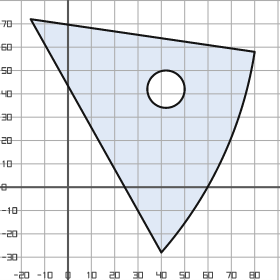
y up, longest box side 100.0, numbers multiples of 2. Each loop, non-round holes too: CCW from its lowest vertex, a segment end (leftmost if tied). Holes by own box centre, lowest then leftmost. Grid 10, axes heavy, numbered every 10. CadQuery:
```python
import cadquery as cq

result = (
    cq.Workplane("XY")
    .moveTo(40.0, -28.0)
    .threePointArc((66.0, 12.0), (80.0, 58.0))
    .lineTo(-16.0, 72.0)
    .close()
    .moveTo(42.0, 42.0)
    .circle(8.0)
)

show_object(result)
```